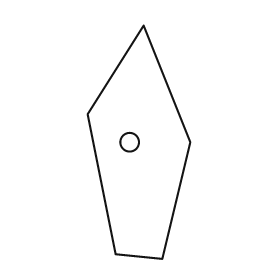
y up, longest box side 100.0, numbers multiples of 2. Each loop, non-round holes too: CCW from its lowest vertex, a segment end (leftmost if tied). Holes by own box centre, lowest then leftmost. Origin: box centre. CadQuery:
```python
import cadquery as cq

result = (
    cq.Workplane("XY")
    .moveTo(10.0, -50.0)
    .lineTo(22.0, 0.0)
    .lineTo(2.0, 50.0)
    .lineTo(-22.0, 12.0)
    .lineTo(-10.0, -48.0)
    .close()
    .moveTo(-4.0, 0.0)
    .circle(4.0)
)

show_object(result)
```